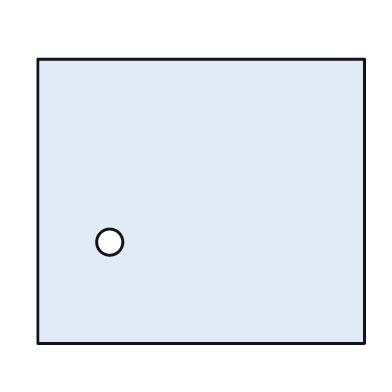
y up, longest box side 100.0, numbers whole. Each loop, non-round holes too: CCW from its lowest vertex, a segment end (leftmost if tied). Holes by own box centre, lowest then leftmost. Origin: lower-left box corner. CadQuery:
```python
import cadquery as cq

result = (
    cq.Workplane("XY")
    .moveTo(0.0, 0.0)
    .lineTo(100.0, 0.0)
    .lineTo(100.0, 87.0)
    .lineTo(0.0, 87.0)
    .close()
    .moveTo(22.0, 31.0)
    .circle(4.0)
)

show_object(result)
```